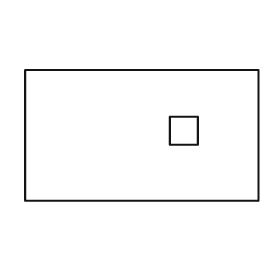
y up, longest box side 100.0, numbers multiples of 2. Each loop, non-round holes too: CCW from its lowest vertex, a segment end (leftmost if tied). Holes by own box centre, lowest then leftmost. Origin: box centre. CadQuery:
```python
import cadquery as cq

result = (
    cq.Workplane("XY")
    .moveTo(-50.0, -28.0)
    .lineTo(50.0, -28.0)
    .lineTo(50.0, 28.0)
    .lineTo(-50.0, 28.0)
    .close()
    .moveTo(12.0, -4.0)
    .lineTo(24.0, -4.0)
    .lineTo(24.0, 8.0)
    .lineTo(12.0, 8.0)
    .close()
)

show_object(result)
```